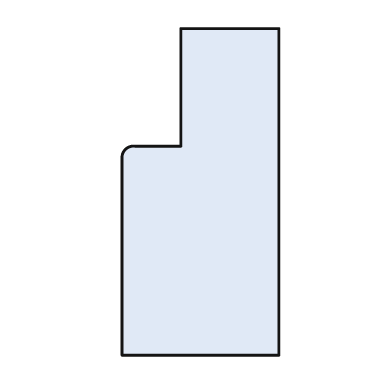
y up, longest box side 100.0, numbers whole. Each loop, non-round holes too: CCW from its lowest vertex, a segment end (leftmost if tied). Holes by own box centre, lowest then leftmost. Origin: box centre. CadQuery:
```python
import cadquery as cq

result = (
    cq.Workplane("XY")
    .moveTo(-24.0, -50.0)
    .lineTo(24.0, -50.0)
    .lineTo(24.0, 50.0)
    .lineTo(-6.0, 50.0)
    .lineTo(-6.0, 14.0)
    .lineTo(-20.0, 14.0)
    .threePointArc((-23.0, 13.0), (-24.0, 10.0))
    .close()
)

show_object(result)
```